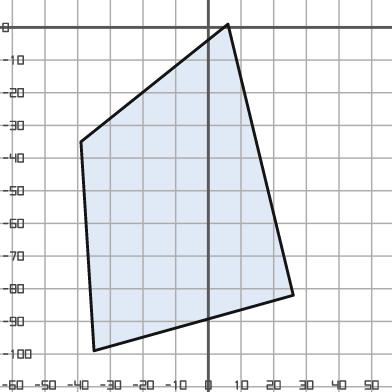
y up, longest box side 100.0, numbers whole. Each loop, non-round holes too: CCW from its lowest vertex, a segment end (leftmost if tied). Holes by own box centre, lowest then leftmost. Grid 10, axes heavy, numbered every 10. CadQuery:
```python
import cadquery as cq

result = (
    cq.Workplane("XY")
    .moveTo(-35.0, -99.0)
    .lineTo(26.0, -82.0)
    .lineTo(6.0, 1.0)
    .lineTo(-39.0, -35.0)
    .close()
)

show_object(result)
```